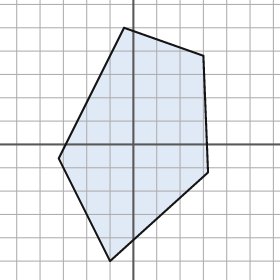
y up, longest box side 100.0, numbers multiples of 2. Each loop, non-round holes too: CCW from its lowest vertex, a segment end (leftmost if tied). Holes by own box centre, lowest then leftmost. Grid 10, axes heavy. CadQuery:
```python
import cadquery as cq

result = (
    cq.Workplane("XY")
    .moveTo(-10.0, -50.0)
    .lineTo(32.0, -12.0)
    .lineTo(30.0, 38.0)
    .lineTo(-4.0, 50.0)
    .lineTo(-32.0, -6.0)
    .close()
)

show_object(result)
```